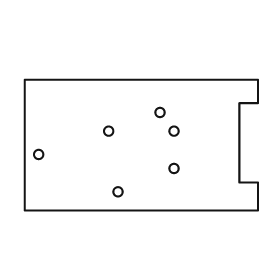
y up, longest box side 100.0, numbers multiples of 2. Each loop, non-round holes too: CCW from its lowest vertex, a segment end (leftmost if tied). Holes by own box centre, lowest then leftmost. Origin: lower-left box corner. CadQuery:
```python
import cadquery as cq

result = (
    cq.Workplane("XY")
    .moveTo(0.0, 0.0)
    .lineTo(100.0, 0.0)
    .lineTo(100.0, 12.0)
    .lineTo(92.0, 12.0)
    .lineTo(92.0, 46.0)
    .lineTo(100.0, 46.0)
    .lineTo(100.0, 56.0)
    .lineTo(0.0, 56.0)
    .close()
    .moveTo(40.0, 8.0)
    .circle(2.0)
    .moveTo(64.0, 18.0)
    .circle(2.0)
    .moveTo(6.0, 24.0)
    .circle(2.0)
    .moveTo(36.0, 34.0)
    .circle(2.0)
    .moveTo(64.0, 34.0)
    .circle(2.0)
    .moveTo(58.0, 42.0)
    .circle(2.0)
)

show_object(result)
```